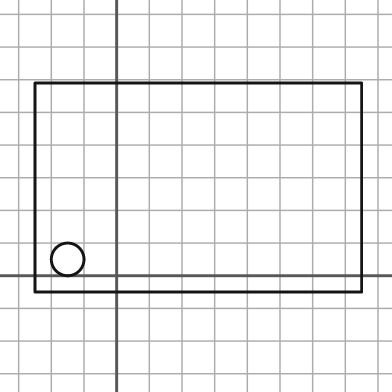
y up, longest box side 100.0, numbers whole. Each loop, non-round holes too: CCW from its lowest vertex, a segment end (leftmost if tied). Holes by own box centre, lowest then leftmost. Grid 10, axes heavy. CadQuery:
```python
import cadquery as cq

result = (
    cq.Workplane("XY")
    .moveTo(-25.0, -5.0)
    .lineTo(75.0, -5.0)
    .lineTo(75.0, 59.0)
    .lineTo(-25.0, 59.0)
    .close()
    .moveTo(-15.0, 5.0)
    .circle(5.0)
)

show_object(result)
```